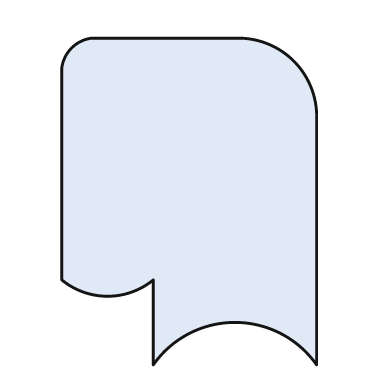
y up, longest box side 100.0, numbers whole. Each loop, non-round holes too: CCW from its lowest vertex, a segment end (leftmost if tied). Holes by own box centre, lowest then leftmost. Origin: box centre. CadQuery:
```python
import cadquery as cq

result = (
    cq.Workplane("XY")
    .moveTo(-11.0, -50.0)
    .threePointArc((14.0, -37.0), (39.0, -50.0))
    .lineTo(39.0, 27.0)
    .threePointArc((32.0, 43.0), (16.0, 50.0))
    .lineTo(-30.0, 50.0)
    .threePointArc((-36.0, 47.0), (-39.0, 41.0))
    .lineTo(-39.0, -24.0)
    .threePointArc((-25.0, -29.0), (-11.0, -24.0))
    .close()
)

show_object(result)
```